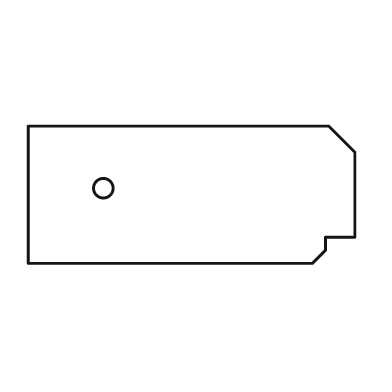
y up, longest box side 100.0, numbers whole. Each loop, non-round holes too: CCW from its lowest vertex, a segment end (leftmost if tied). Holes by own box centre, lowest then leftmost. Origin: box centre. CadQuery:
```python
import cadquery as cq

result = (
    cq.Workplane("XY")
    .moveTo(-50.0, -21.0)
    .lineTo(37.0, -21.0)
    .lineTo(41.0, -17.0)
    .lineTo(41.0, -13.0)
    .lineTo(50.0, -13.0)
    .lineTo(50.0, 13.0)
    .lineTo(42.0, 21.0)
    .lineTo(-50.0, 21.0)
    .close()
    .moveTo(-27.0, 2.0)
    .circle(3.0)
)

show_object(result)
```